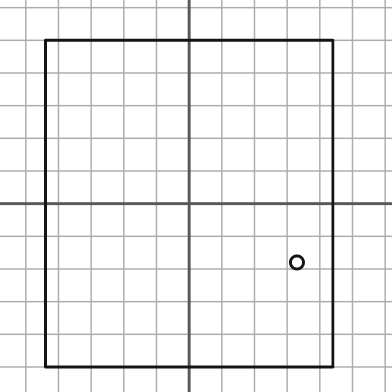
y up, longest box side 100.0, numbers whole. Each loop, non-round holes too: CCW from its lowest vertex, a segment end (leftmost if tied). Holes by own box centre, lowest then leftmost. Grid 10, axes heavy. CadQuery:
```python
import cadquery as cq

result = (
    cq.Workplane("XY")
    .moveTo(-44.0, -50.0)
    .lineTo(44.0, -50.0)
    .lineTo(44.0, 50.0)
    .lineTo(-44.0, 50.0)
    .close()
    .moveTo(33.0, -18.0)
    .circle(2.0)
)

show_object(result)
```